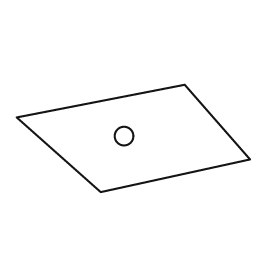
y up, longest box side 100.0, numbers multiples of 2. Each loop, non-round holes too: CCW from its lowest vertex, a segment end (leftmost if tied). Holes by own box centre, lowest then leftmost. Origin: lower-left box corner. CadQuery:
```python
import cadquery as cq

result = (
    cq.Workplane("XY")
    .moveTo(36.0, 0.0)
    .lineTo(100.0, 14.0)
    .lineTo(72.0, 46.0)
    .lineTo(0.0, 32.0)
    .close()
    .moveTo(46.0, 24.0)
    .circle(4.0)
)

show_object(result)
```